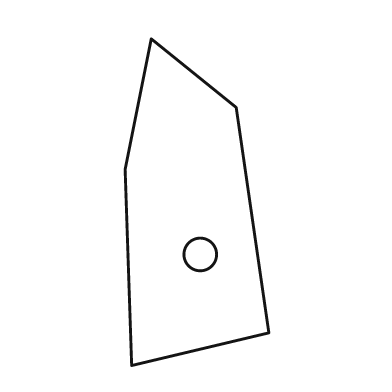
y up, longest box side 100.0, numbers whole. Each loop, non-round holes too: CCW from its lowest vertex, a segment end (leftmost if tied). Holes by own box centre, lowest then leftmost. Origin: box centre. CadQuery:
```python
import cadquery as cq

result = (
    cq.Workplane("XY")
    .moveTo(-20.0, -50.0)
    .lineTo(22.0, -40.0)
    .lineTo(12.0, 29.0)
    .lineTo(-14.0, 50.0)
    .lineTo(-22.0, 10.0)
    .close()
    .moveTo(1.0, -16.0)
    .circle(5.0)
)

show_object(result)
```